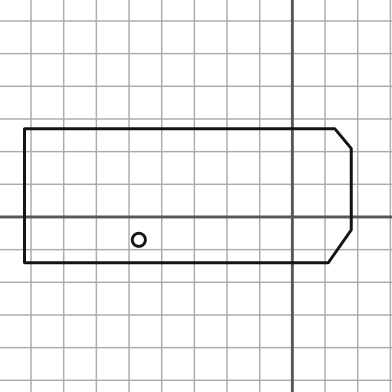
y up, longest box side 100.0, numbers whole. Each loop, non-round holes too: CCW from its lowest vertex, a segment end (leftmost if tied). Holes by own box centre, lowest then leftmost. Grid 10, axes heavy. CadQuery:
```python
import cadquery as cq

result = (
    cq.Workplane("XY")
    .moveTo(-82.0, -14.0)
    .lineTo(11.0, -14.0)
    .lineTo(18.0, -4.0)
    .lineTo(18.0, 21.0)
    .lineTo(13.0, 27.0)
    .lineTo(-82.0, 27.0)
    .close()
    .moveTo(-47.0, -7.0)
    .circle(2.0)
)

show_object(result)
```